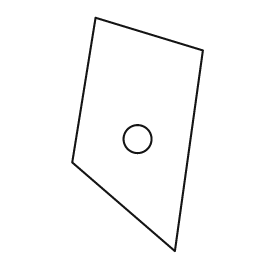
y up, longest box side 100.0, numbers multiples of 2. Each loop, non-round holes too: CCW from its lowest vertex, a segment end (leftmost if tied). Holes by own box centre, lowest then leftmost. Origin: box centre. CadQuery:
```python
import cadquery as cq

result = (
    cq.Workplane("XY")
    .moveTo(16.0, -50.0)
    .lineTo(28.0, 36.0)
    .lineTo(-18.0, 50.0)
    .lineTo(-28.0, -12.0)
    .close()
    .moveTo(0.0, -2.0)
    .circle(6.0)
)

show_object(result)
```